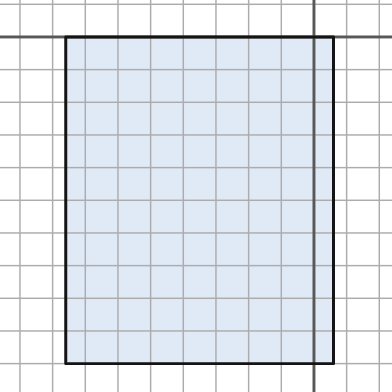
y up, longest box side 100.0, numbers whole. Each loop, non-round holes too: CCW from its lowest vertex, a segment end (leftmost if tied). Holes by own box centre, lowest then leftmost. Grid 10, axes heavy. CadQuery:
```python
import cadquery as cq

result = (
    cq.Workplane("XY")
    .moveTo(-76.0, -100.0)
    .lineTo(6.0, -100.0)
    .lineTo(6.0, 0.0)
    .lineTo(-76.0, 0.0)
    .close()
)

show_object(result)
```